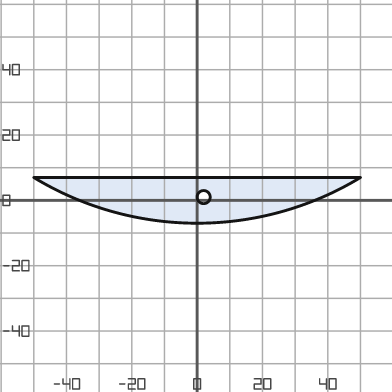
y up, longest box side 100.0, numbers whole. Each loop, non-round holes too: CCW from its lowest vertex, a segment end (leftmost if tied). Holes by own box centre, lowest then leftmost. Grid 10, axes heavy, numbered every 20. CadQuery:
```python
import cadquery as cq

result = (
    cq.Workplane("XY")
    .moveTo(-50.0, 7.0)
    .threePointArc((0.0, -7.0), (50.0, 7.0))
    .close()
    .moveTo(2.0, 1.0)
    .circle(2.0)
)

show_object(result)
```